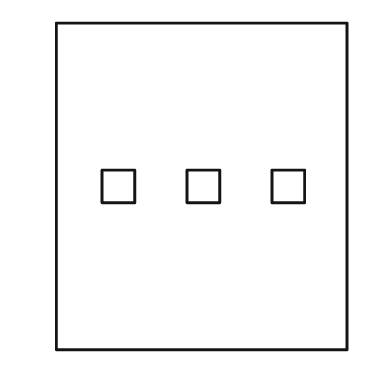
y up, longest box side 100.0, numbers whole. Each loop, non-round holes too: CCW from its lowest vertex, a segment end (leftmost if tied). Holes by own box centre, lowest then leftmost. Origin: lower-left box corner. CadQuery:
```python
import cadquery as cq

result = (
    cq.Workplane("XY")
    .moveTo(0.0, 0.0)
    .lineTo(89.0, 0.0)
    .lineTo(89.0, 100.0)
    .lineTo(0.0, 100.0)
    .close()
    .moveTo(14.0, 45.0)
    .lineTo(24.0, 45.0)
    .lineTo(24.0, 55.0)
    .lineTo(14.0, 55.0)
    .close()
    .moveTo(40.0, 45.0)
    .lineTo(50.0, 45.0)
    .lineTo(50.0, 55.0)
    .lineTo(40.0, 55.0)
    .close()
    .moveTo(66.0, 45.0)
    .lineTo(76.0, 45.0)
    .lineTo(76.0, 55.0)
    .lineTo(66.0, 55.0)
    .close()
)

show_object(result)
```